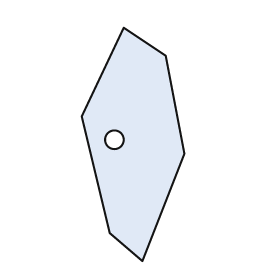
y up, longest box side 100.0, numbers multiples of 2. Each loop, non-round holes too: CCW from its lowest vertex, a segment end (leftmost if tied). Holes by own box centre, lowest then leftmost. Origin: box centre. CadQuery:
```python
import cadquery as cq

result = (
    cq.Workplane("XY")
    .moveTo(4.0, -50.0)
    .lineTo(22.0, -4.0)
    .lineTo(14.0, 38.0)
    .lineTo(-4.0, 50.0)
    .lineTo(-22.0, 12.0)
    .lineTo(-10.0, -38.0)
    .close()
    .moveTo(-8.0, 2.0)
    .circle(4.0)
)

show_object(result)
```